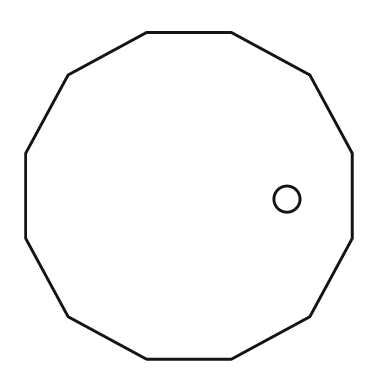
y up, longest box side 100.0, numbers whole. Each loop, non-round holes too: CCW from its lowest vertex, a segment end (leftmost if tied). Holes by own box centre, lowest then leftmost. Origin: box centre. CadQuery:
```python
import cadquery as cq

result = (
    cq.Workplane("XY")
    .moveTo(-13.0, -50.0)
    .lineTo(13.0, -50.0)
    .lineTo(37.0, -37.0)
    .lineTo(50.0, -13.0)
    .lineTo(50.0, 13.0)
    .lineTo(37.0, 37.0)
    .lineTo(13.0, 50.0)
    .lineTo(-13.0, 50.0)
    .lineTo(-37.0, 37.0)
    .lineTo(-50.0, 13.0)
    .lineTo(-50.0, -13.0)
    .lineTo(-37.0, -37.0)
    .close()
    .moveTo(30.0, -1.0)
    .circle(4.0)
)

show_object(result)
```